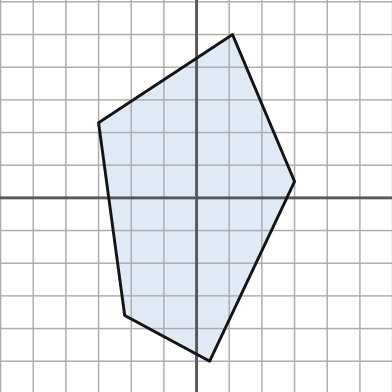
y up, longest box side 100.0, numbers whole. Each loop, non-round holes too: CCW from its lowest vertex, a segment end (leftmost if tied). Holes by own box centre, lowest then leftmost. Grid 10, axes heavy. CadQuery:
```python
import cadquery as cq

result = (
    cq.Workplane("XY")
    .moveTo(4.0, -50.0)
    .lineTo(30.0, 5.0)
    .lineTo(11.0, 50.0)
    .lineTo(-30.0, 23.0)
    .lineTo(-22.0, -36.0)
    .close()
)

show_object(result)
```